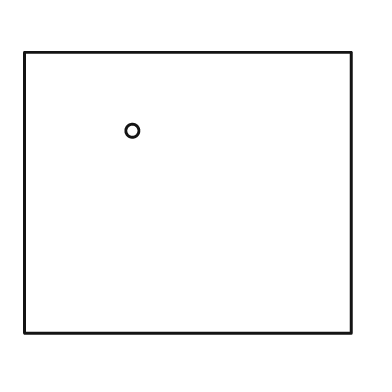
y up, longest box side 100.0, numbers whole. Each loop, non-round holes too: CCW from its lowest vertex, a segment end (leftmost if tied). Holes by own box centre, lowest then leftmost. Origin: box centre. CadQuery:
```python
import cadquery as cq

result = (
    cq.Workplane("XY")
    .moveTo(-50.0, -43.0)
    .lineTo(50.0, -43.0)
    .lineTo(50.0, 43.0)
    .lineTo(-50.0, 43.0)
    .close()
    .moveTo(-17.0, 19.0)
    .circle(2.0)
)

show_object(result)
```